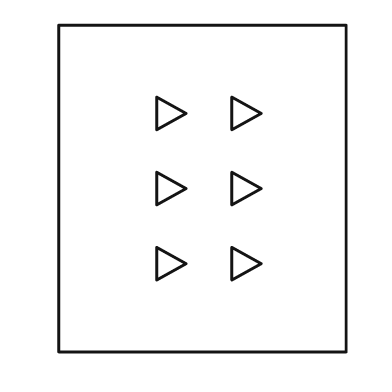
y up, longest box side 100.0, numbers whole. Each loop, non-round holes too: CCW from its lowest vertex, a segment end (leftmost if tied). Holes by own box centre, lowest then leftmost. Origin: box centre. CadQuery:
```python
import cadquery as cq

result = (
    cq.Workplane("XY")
    .moveTo(-44.0, -50.0)
    .lineTo(44.0, -50.0)
    .lineTo(44.0, 50.0)
    .lineTo(-44.0, 50.0)
    .close()
    .moveTo(-14.0, -28.0)
    .lineTo(-5.0, -23.0)
    .lineTo(-14.0, -18.0)
    .close()
    .moveTo(9.0, -28.0)
    .lineTo(18.0, -23.0)
    .lineTo(9.0, -18.0)
    .close()
    .moveTo(-14.0, -5.0)
    .lineTo(-5.0, 0.0)
    .lineTo(-14.0, 5.0)
    .close()
    .moveTo(9.0, -5.0)
    .lineTo(18.0, 0.0)
    .lineTo(9.0, 5.0)
    .close()
    .moveTo(-14.0, 18.0)
    .lineTo(-5.0, 23.0)
    .lineTo(-14.0, 28.0)
    .close()
    .moveTo(9.0, 18.0)
    .lineTo(18.0, 23.0)
    .lineTo(9.0, 28.0)
    .close()
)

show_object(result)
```